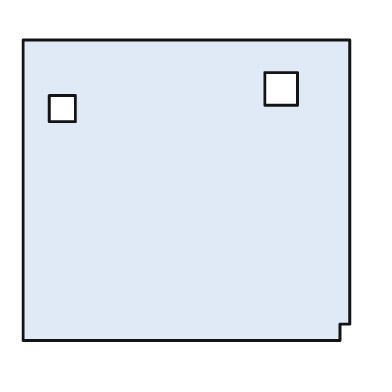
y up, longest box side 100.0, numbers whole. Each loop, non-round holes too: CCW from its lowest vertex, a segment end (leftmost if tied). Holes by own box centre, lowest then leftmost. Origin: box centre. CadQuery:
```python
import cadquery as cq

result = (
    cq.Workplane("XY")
    .moveTo(-50.0, -46.0)
    .lineTo(47.0, -46.0)
    .lineTo(47.0, -41.0)
    .lineTo(50.0, -41.0)
    .lineTo(50.0, 46.0)
    .lineTo(-50.0, 46.0)
    .close()
    .moveTo(-42.0, 21.0)
    .lineTo(-34.0, 21.0)
    .lineTo(-34.0, 29.0)
    .lineTo(-42.0, 29.0)
    .close()
    .moveTo(24.0, 26.0)
    .lineTo(34.0, 26.0)
    .lineTo(34.0, 36.0)
    .lineTo(24.0, 36.0)
    .close()
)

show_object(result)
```